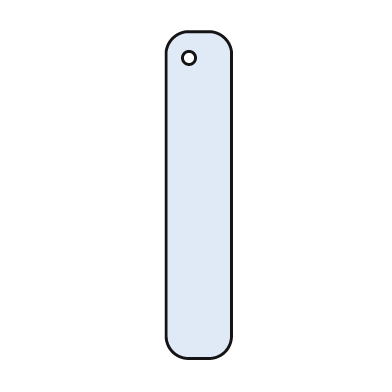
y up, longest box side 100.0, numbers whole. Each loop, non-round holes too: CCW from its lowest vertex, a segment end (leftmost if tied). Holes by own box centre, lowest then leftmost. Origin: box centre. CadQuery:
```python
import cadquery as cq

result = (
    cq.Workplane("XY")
    .moveTo(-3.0, -50.0)
    .lineTo(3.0, -50.0)
    .threePointArc((8.0, -48.0), (10.0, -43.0))
    .lineTo(10.0, 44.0)
    .threePointArc((8.0, 48.0), (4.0, 50.0))
    .lineTo(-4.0, 50.0)
    .threePointArc((-8.0, 48.0), (-10.0, 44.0))
    .lineTo(-10.0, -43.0)
    .threePointArc((-8.0, -48.0), (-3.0, -50.0))
    .close()
    .moveTo(-3.0, 42.0)
    .circle(2.0)
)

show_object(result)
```